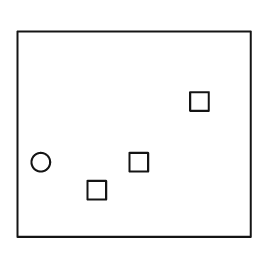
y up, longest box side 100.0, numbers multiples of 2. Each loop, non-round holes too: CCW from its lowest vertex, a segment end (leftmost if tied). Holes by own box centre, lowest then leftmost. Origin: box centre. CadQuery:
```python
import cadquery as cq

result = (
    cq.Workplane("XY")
    .moveTo(-50.0, -44.0)
    .lineTo(50.0, -44.0)
    .lineTo(50.0, 44.0)
    .lineTo(-50.0, 44.0)
    .close()
    .moveTo(-20.0, -28.0)
    .lineTo(-12.0, -28.0)
    .lineTo(-12.0, -20.0)
    .lineTo(-20.0, -20.0)
    .close()
    .moveTo(-40.0, -12.0)
    .circle(4.0)
    .moveTo(-2.0, -16.0)
    .lineTo(6.0, -16.0)
    .lineTo(6.0, -8.0)
    .lineTo(-2.0, -8.0)
    .close()
    .moveTo(24.0, 10.0)
    .lineTo(32.0, 10.0)
    .lineTo(32.0, 18.0)
    .lineTo(24.0, 18.0)
    .close()
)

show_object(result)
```